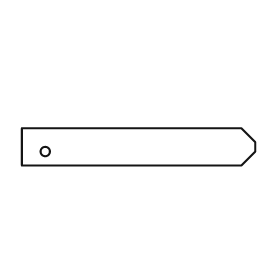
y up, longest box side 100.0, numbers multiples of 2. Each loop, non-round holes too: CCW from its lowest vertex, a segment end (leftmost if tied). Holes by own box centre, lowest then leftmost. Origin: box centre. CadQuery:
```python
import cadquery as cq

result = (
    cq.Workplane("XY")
    .moveTo(-50.0, -8.0)
    .lineTo(44.0, -8.0)
    .lineTo(50.0, -2.0)
    .lineTo(50.0, 2.0)
    .lineTo(44.0, 8.0)
    .lineTo(-50.0, 8.0)
    .close()
    .moveTo(-40.0, -2.0)
    .circle(2.0)
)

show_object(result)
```